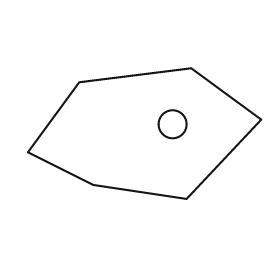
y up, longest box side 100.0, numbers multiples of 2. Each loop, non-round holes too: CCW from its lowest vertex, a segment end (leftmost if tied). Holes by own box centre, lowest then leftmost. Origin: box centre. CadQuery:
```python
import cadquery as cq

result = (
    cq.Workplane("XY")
    .moveTo(18.0, -28.0)
    .lineTo(50.0, 6.0)
    .lineTo(20.0, 28.0)
    .lineTo(-28.0, 22.0)
    .lineTo(-50.0, -8.0)
    .lineTo(-22.0, -22.0)
    .close()
    .moveTo(12.0, 4.0)
    .circle(6.0)
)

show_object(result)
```